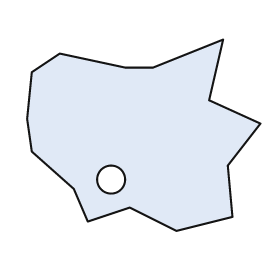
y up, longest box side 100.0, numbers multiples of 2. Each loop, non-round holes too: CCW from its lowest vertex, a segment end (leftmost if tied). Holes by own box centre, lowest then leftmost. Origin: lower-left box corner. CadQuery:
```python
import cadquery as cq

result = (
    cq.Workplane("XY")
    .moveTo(64.0, 0.0)
    .lineTo(88.0, 6.0)
    .lineTo(86.0, 28.0)
    .lineTo(100.0, 46.0)
    .lineTo(78.0, 56.0)
    .lineTo(84.0, 82.0)
    .lineTo(54.0, 70.0)
    .lineTo(42.0, 70.0)
    .lineTo(14.0, 76.0)
    .lineTo(2.0, 68.0)
    .lineTo(0.0, 48.0)
    .lineTo(2.0, 34.0)
    .lineTo(20.0, 18.0)
    .lineTo(26.0, 4.0)
    .lineTo(44.0, 10.0)
    .close()
    .moveTo(36.0, 22.0)
    .circle(6.0)
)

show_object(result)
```